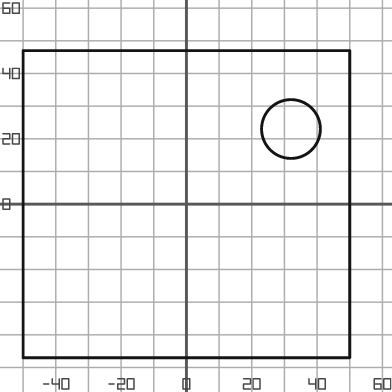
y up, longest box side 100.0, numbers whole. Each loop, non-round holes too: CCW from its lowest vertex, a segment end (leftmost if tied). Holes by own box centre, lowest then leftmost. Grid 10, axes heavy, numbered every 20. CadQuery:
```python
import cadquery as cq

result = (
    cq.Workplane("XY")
    .moveTo(-50.0, -47.0)
    .lineTo(50.0, -47.0)
    .lineTo(50.0, 47.0)
    .lineTo(-50.0, 47.0)
    .close()
    .moveTo(32.0, 23.0)
    .circle(9.0)
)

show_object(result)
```